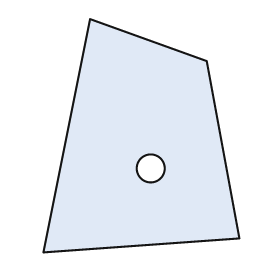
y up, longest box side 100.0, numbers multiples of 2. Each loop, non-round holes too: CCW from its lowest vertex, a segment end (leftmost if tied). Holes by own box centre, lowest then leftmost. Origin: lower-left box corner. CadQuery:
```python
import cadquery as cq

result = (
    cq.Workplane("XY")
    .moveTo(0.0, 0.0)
    .lineTo(84.0, 6.0)
    .lineTo(70.0, 82.0)
    .lineTo(20.0, 100.0)
    .close()
    .moveTo(46.0, 36.0)
    .circle(6.0)
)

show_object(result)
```